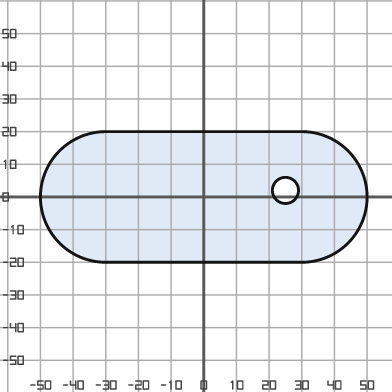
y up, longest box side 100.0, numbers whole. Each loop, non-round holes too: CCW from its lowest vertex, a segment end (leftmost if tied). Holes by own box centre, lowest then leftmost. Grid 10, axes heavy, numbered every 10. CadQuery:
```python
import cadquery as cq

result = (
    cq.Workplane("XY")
    .moveTo(-30.0, -20.0)
    .lineTo(30.0, -20.0)
    .threePointArc((50.0, 0.0), (30.0, 20.0))
    .lineTo(-30.0, 20.0)
    .threePointArc((-50.0, 0.0), (-30.0, -20.0))
    .close()
    .moveTo(25.0, 2.0)
    .circle(4.0)
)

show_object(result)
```